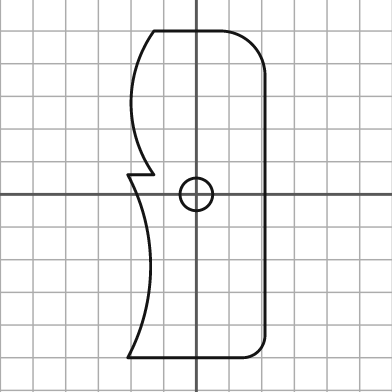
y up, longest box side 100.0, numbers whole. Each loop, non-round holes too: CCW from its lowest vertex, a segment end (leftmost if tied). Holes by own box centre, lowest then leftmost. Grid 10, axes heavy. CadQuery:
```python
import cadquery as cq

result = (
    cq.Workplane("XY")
    .moveTo(-21.0, -50.0)
    .lineTo(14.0, -50.0)
    .threePointArc((19.0, -48.0), (21.0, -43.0))
    .lineTo(21.0, 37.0)
    .threePointArc((17.0, 46.0), (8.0, 50.0))
    .lineTo(-13.0, 50.0)
    .threePointArc((-20.0, 28.0), (-13.0, 6.0))
    .lineTo(-21.0, 6.0)
    .threePointArc((-14.0, -22.0), (-21.0, -50.0))
    .close()
    .moveTo(0.0, 0.0)
    .circle(5.0)
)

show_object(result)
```